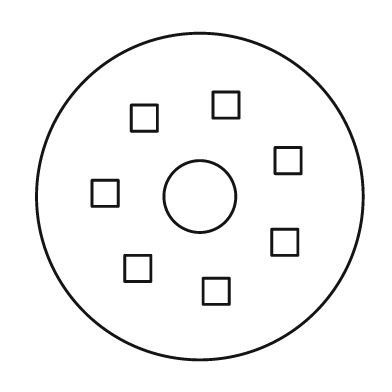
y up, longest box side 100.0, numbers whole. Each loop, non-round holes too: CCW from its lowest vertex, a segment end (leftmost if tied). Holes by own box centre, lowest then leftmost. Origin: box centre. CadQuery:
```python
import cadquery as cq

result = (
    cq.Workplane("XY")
    .moveTo(0.0, 0.0)
    .circle(50.0)
    .moveTo(1.0, -33.0)
    .lineTo(9.0, -33.0)
    .lineTo(9.0, -25.0)
    .lineTo(1.0, -25.0)
    .close()
    .moveTo(-23.0, -26.0)
    .lineTo(-15.0, -26.0)
    .lineTo(-15.0, -18.0)
    .lineTo(-23.0, -18.0)
    .close()
    .moveTo(22.0, -18.0)
    .lineTo(30.0, -18.0)
    .lineTo(30.0, -10.0)
    .lineTo(22.0, -10.0)
    .close()
    .moveTo(0.0, 0.0)
    .circle(11.0)
    .moveTo(-33.0, -3.0)
    .lineTo(-25.0, -3.0)
    .lineTo(-25.0, 5.0)
    .lineTo(-33.0, 5.0)
    .close()
    .moveTo(23.0, 7.0)
    .lineTo(31.0, 7.0)
    .lineTo(31.0, 15.0)
    .lineTo(23.0, 15.0)
    .close()
    .moveTo(-21.0, 20.0)
    .lineTo(-13.0, 20.0)
    .lineTo(-13.0, 28.0)
    .lineTo(-21.0, 28.0)
    .close()
    .moveTo(4.0, 24.0)
    .lineTo(12.0, 24.0)
    .lineTo(12.0, 32.0)
    .lineTo(4.0, 32.0)
    .close()
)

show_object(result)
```